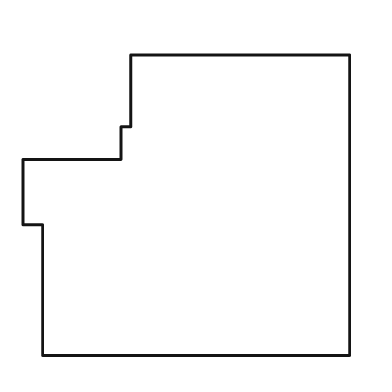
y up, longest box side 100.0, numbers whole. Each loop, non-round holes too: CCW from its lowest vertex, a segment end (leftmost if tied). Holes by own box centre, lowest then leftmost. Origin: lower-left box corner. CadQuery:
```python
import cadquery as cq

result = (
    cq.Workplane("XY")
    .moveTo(6.0, 0.0)
    .lineTo(100.0, 0.0)
    .lineTo(100.0, 92.0)
    .lineTo(33.0, 92.0)
    .lineTo(33.0, 70.0)
    .lineTo(30.0, 70.0)
    .lineTo(30.0, 60.0)
    .lineTo(0.0, 60.0)
    .lineTo(0.0, 40.0)
    .lineTo(6.0, 40.0)
    .close()
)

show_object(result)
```